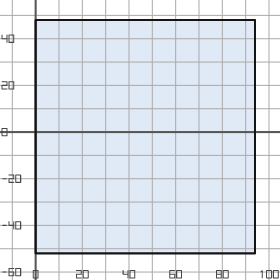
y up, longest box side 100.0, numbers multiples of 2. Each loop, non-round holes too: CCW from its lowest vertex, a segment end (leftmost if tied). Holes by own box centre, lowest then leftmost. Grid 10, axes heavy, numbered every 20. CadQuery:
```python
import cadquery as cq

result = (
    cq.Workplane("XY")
    .moveTo(0.0, -52.0)
    .lineTo(94.0, -52.0)
    .lineTo(94.0, 48.0)
    .lineTo(0.0, 48.0)
    .close()
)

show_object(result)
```